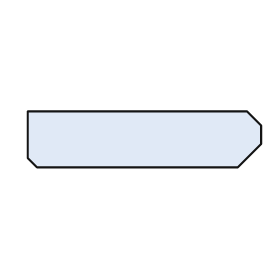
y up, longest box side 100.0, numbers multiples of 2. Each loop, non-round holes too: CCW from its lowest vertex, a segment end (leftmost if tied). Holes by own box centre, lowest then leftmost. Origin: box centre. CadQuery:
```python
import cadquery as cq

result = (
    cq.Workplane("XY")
    .moveTo(-46.0, -12.0)
    .lineTo(40.0, -12.0)
    .lineTo(50.0, -2.0)
    .lineTo(50.0, 6.0)
    .lineTo(44.0, 12.0)
    .lineTo(-50.0, 12.0)
    .lineTo(-50.0, -8.0)
    .close()
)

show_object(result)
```